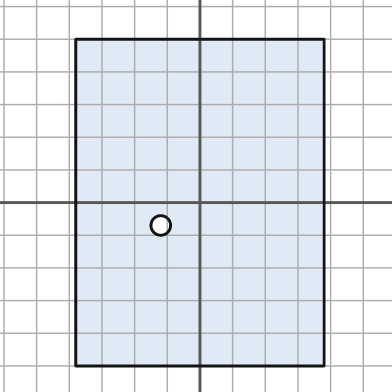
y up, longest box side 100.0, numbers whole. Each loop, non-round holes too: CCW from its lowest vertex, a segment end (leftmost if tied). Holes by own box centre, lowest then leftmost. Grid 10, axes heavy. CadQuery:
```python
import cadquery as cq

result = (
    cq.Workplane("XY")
    .moveTo(-38.0, -50.0)
    .lineTo(38.0, -50.0)
    .lineTo(38.0, 50.0)
    .lineTo(-38.0, 50.0)
    .close()
    .moveTo(-12.0, -7.0)
    .circle(3.0)
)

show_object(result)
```